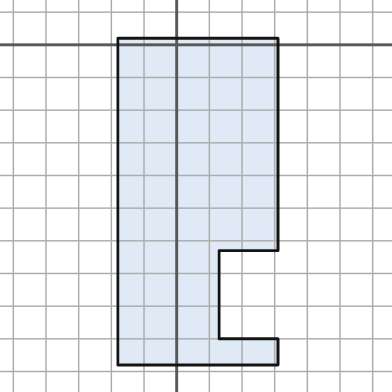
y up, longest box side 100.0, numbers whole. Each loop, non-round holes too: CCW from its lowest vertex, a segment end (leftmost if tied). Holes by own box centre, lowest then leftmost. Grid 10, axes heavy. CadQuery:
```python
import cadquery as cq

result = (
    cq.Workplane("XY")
    .moveTo(-18.0, -98.0)
    .lineTo(31.0, -98.0)
    .lineTo(31.0, -90.0)
    .lineTo(13.0, -90.0)
    .lineTo(13.0, -63.0)
    .lineTo(31.0, -63.0)
    .lineTo(31.0, 2.0)
    .lineTo(-18.0, 2.0)
    .close()
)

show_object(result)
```